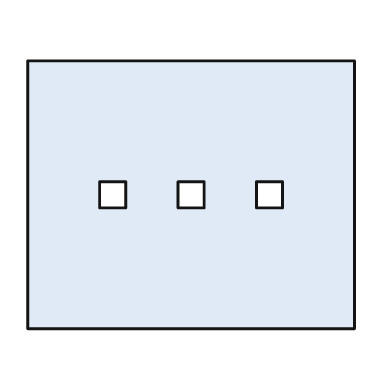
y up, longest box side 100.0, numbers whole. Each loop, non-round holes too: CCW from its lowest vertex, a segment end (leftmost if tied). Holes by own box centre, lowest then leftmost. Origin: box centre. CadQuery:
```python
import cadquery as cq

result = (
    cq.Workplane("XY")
    .moveTo(-50.0, -41.0)
    .lineTo(50.0, -41.0)
    .lineTo(50.0, 41.0)
    .lineTo(-50.0, 41.0)
    .close()
    .moveTo(-28.0, -4.0)
    .lineTo(-20.0, -4.0)
    .lineTo(-20.0, 4.0)
    .lineTo(-28.0, 4.0)
    .close()
    .moveTo(-4.0, -4.0)
    .lineTo(4.0, -4.0)
    .lineTo(4.0, 4.0)
    .lineTo(-4.0, 4.0)
    .close()
    .moveTo(20.0, -4.0)
    .lineTo(28.0, -4.0)
    .lineTo(28.0, 4.0)
    .lineTo(20.0, 4.0)
    .close()
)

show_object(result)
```